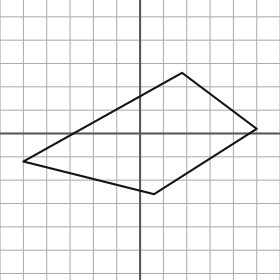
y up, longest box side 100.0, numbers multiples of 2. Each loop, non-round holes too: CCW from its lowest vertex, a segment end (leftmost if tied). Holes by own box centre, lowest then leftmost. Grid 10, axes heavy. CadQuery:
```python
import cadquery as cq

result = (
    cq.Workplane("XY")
    .moveTo(6.0, -26.0)
    .lineTo(50.0, 2.0)
    .lineTo(18.0, 26.0)
    .lineTo(-50.0, -12.0)
    .close()
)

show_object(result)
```